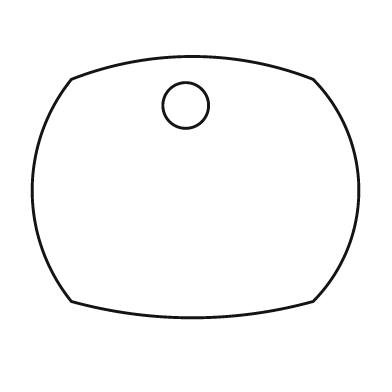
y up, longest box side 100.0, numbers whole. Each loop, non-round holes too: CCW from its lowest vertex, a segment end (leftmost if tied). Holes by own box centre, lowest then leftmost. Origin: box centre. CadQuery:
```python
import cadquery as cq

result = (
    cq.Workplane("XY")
    .moveTo(-38.0, -35.0)
    .threePointArc((-1.0, -40.0), (36.0, -35.0))
    .threePointArc((50.0, -1.0), (36.0, 33.0))
    .threePointArc((-1.0, 40.0), (-38.0, 33.0))
    .threePointArc((-50.0, -1.0), (-38.0, -35.0))
    .close()
    .moveTo(-3.0, 25.0)
    .circle(7.0)
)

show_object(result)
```